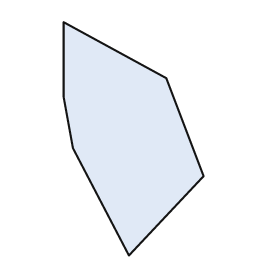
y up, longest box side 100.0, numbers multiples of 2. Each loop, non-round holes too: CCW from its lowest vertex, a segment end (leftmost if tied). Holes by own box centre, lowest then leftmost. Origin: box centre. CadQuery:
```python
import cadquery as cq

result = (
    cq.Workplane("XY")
    .moveTo(-2.0, -50.0)
    .lineTo(30.0, -16.0)
    .lineTo(14.0, 26.0)
    .lineTo(-30.0, 50.0)
    .lineTo(-30.0, 18.0)
    .lineTo(-26.0, -4.0)
    .close()
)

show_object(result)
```